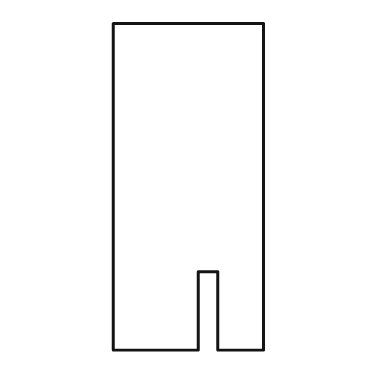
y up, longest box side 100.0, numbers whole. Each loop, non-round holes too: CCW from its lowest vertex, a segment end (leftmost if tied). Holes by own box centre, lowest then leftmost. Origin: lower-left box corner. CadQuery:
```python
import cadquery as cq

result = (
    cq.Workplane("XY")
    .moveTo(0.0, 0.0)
    .lineTo(26.0, 0.0)
    .lineTo(26.0, 24.0)
    .lineTo(32.0, 24.0)
    .lineTo(32.0, 0.0)
    .lineTo(46.0, 0.0)
    .lineTo(46.0, 100.0)
    .lineTo(0.0, 100.0)
    .close()
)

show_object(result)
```